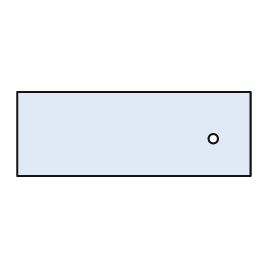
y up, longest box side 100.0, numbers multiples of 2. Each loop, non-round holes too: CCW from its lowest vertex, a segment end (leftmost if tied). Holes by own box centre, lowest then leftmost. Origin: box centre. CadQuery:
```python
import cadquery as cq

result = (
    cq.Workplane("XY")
    .moveTo(-50.0, -18.0)
    .lineTo(50.0, -18.0)
    .lineTo(50.0, 18.0)
    .lineTo(-50.0, 18.0)
    .close()
    .moveTo(34.0, -2.0)
    .circle(2.0)
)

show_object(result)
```